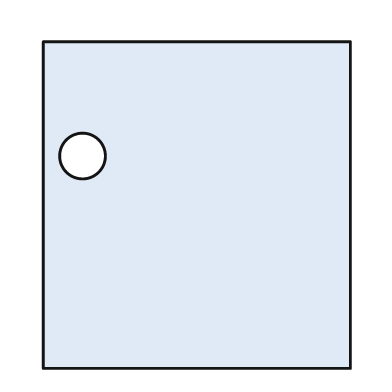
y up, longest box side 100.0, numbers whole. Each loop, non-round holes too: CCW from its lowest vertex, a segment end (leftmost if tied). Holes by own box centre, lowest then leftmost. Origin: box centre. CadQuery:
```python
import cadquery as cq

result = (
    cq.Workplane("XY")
    .moveTo(-47.0, -50.0)
    .lineTo(47.0, -50.0)
    .lineTo(47.0, 50.0)
    .lineTo(-47.0, 50.0)
    .close()
    .moveTo(-35.0, 15.0)
    .circle(7.0)
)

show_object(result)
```